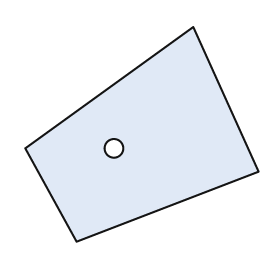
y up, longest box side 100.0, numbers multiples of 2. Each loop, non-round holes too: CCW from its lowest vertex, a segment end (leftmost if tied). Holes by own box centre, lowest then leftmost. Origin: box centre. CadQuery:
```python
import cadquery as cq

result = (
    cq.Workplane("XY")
    .moveTo(-28.0, -46.0)
    .lineTo(50.0, -16.0)
    .lineTo(22.0, 46.0)
    .lineTo(-50.0, -6.0)
    .close()
    .moveTo(-12.0, -6.0)
    .circle(4.0)
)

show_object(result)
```